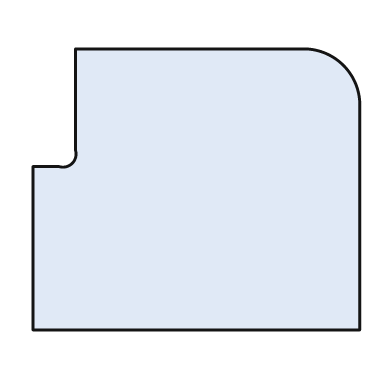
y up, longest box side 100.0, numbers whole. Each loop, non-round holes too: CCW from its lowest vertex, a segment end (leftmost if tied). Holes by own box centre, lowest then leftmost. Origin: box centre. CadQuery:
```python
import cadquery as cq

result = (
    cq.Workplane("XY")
    .moveTo(-50.0, -43.0)
    .lineTo(50.0, -43.0)
    .lineTo(50.0, 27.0)
    .threePointArc((45.0, 38.0), (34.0, 43.0))
    .lineTo(-37.0, 43.0)
    .lineTo(-37.0, 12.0)
    .threePointArc((-38.0, 8.0), (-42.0, 7.0))
    .lineTo(-50.0, 7.0)
    .close()
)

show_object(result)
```